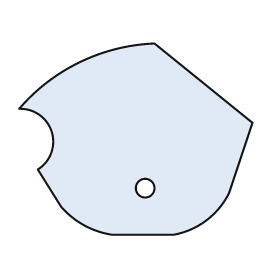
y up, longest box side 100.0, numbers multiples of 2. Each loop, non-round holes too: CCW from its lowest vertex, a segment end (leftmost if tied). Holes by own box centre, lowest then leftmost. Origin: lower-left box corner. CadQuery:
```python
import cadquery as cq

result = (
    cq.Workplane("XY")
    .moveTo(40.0, 0.0)
    .lineTo(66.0, 0.0)
    .threePointArc((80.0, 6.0), (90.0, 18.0))
    .lineTo(100.0, 48.0)
    .lineTo(58.0, 82.0)
    .threePointArc((26.0, 74.0), (0.0, 54.0))
    .threePointArc((14.0, 44.0), (8.0, 28.0))
    .lineTo(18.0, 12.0)
    .threePointArc((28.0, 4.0), (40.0, 0.0))
    .close()
    .moveTo(54.0, 20.0)
    .circle(4.0)
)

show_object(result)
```